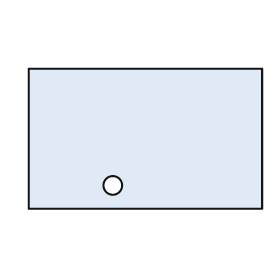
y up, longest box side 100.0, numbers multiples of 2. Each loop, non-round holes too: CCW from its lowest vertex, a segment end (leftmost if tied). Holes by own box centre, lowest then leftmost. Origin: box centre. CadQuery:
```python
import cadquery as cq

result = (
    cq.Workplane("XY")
    .moveTo(-50.0, -30.0)
    .lineTo(50.0, -30.0)
    .lineTo(50.0, 30.0)
    .lineTo(-50.0, 30.0)
    .close()
    .moveTo(-14.0, -20.0)
    .circle(4.0)
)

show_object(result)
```